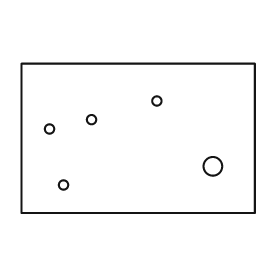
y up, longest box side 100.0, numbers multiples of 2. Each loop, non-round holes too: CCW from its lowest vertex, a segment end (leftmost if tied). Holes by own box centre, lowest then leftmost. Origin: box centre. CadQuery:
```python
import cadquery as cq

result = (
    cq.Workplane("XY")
    .moveTo(-50.0, -32.0)
    .lineTo(50.0, -32.0)
    .lineTo(50.0, 32.0)
    .lineTo(-50.0, 32.0)
    .close()
    .moveTo(-32.0, -20.0)
    .circle(2.0)
    .moveTo(32.0, -12.0)
    .circle(4.0)
    .moveTo(-38.0, 4.0)
    .circle(2.0)
    .moveTo(-20.0, 8.0)
    .circle(2.0)
    .moveTo(8.0, 16.0)
    .circle(2.0)
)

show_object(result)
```